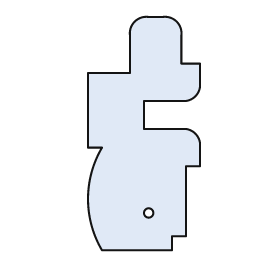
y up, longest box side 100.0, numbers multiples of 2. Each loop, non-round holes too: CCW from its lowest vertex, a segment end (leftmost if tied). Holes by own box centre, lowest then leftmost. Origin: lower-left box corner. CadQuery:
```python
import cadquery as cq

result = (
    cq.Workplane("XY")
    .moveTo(6.0, 0.0)
    .lineTo(36.0, 0.0)
    .lineTo(36.0, 6.0)
    .lineTo(42.0, 6.0)
    .lineTo(42.0, 36.0)
    .lineTo(48.0, 36.0)
    .lineTo(48.0, 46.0)
    .threePointArc((46.0, 50.0), (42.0, 52.0))
    .lineTo(24.0, 52.0)
    .lineTo(24.0, 64.0)
    .lineTo(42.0, 64.0)
    .threePointArc((46.0, 66.0), (48.0, 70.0))
    .lineTo(48.0, 80.0)
    .lineTo(40.0, 80.0)
    .lineTo(40.0, 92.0)
    .threePointArc((38.0, 98.0), (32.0, 100.0))
    .lineTo(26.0, 100.0)
    .threePointArc((20.0, 98.0), (18.0, 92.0))
    .lineTo(18.0, 76.0)
    .lineTo(0.0, 76.0)
    .lineTo(0.0, 44.0)
    .lineTo(6.0, 44.0)
    .threePointArc((0.0, 22.0), (6.0, 0.0))
    .close()
    .moveTo(26.0, 16.0)
    .circle(2.0)
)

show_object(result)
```